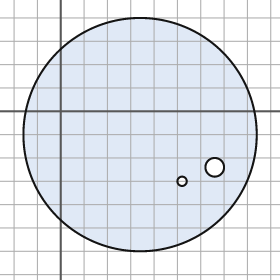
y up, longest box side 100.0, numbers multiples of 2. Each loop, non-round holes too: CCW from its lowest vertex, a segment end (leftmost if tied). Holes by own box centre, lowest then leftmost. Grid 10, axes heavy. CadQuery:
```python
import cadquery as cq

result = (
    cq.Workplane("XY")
    .moveTo(34.0, -10.0)
    .circle(50.0)
    .moveTo(52.0, -30.0)
    .circle(2.0)
    .moveTo(66.0, -24.0)
    .circle(4.0)
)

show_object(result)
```